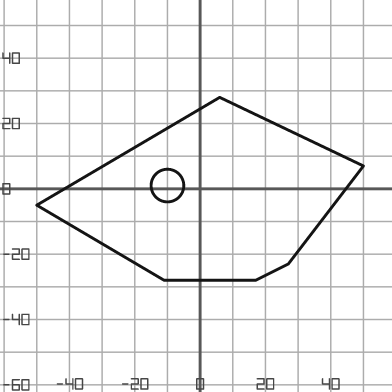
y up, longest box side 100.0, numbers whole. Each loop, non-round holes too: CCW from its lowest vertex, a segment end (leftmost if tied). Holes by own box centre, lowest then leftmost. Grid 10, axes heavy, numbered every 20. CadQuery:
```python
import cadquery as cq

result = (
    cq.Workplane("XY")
    .moveTo(-11.0, -28.0)
    .lineTo(17.0, -28.0)
    .lineTo(27.0, -23.0)
    .lineTo(50.0, 7.0)
    .lineTo(6.0, 28.0)
    .lineTo(-50.0, -5.0)
    .close()
    .moveTo(-10.0, 1.0)
    .circle(5.0)
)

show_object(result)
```